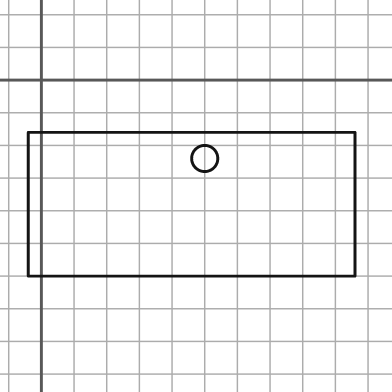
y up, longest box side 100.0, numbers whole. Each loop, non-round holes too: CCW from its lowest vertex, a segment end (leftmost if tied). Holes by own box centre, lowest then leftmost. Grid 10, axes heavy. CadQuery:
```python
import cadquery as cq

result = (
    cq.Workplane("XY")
    .moveTo(-4.0, -60.0)
    .lineTo(96.0, -60.0)
    .lineTo(96.0, -16.0)
    .lineTo(-4.0, -16.0)
    .close()
    .moveTo(50.0, -24.0)
    .circle(4.0)
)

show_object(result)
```